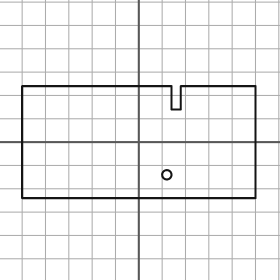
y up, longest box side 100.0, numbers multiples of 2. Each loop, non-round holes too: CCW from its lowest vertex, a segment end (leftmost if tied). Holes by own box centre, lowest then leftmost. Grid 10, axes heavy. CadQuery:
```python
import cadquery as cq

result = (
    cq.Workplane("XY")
    .moveTo(-50.0, -24.0)
    .lineTo(50.0, -24.0)
    .lineTo(50.0, 24.0)
    .lineTo(18.0, 24.0)
    .lineTo(18.0, 14.0)
    .lineTo(14.0, 14.0)
    .lineTo(14.0, 24.0)
    .lineTo(-50.0, 24.0)
    .close()
    .moveTo(12.0, -14.0)
    .circle(2.0)
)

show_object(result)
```